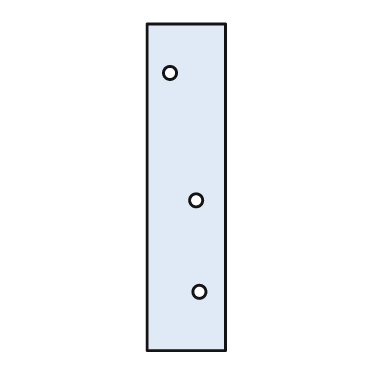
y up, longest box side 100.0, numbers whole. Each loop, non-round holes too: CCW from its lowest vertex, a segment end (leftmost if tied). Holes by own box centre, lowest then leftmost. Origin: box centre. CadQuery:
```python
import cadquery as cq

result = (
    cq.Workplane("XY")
    .moveTo(-12.0, -50.0)
    .lineTo(12.0, -50.0)
    .lineTo(12.0, 50.0)
    .lineTo(-12.0, 50.0)
    .close()
    .moveTo(4.0, -32.0)
    .circle(2.0)
    .moveTo(3.0, -4.0)
    .circle(2.0)
    .moveTo(-5.0, 35.0)
    .circle(2.0)
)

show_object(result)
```